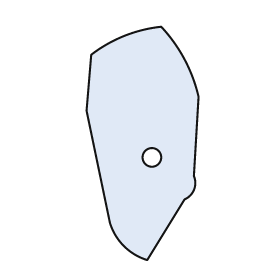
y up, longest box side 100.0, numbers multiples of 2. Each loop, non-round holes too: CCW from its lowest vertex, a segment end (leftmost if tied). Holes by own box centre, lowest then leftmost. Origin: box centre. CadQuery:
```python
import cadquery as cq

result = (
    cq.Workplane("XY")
    .moveTo(2.0, -50.0)
    .lineTo(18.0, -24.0)
    .threePointArc((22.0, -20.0), (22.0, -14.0))
    .lineTo(24.0, 20.0)
    .threePointArc((18.0, 36.0), (8.0, 50.0))
    .threePointArc((-8.0, 46.0), (-22.0, 38.0))
    .lineTo(-24.0, 14.0)
    .lineTo(-14.0, -34.0)
    .threePointArc((-8.0, -44.0), (2.0, -50.0))
    .close()
    .moveTo(4.0, -6.0)
    .circle(4.0)
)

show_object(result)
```